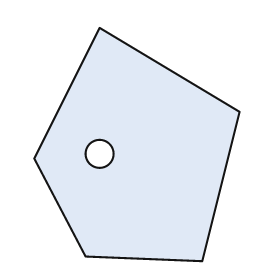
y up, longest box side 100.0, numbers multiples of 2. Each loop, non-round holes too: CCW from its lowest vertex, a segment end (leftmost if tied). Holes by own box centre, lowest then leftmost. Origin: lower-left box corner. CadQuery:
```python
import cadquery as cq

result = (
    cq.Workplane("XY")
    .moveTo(72.0, 0.0)
    .lineTo(88.0, 64.0)
    .lineTo(28.0, 100.0)
    .lineTo(0.0, 44.0)
    .lineTo(22.0, 2.0)
    .close()
    .moveTo(28.0, 46.0)
    .circle(6.0)
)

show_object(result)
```